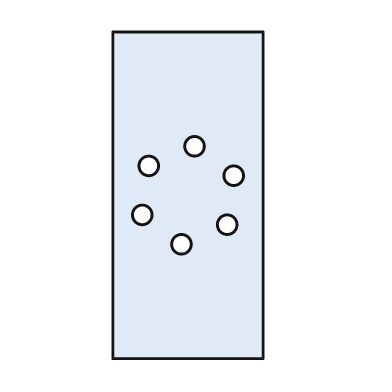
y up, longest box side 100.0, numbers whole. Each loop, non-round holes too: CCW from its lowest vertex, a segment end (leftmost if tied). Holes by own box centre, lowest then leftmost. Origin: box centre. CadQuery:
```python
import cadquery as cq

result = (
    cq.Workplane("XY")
    .moveTo(-23.0, -50.0)
    .lineTo(23.0, -50.0)
    .lineTo(23.0, 50.0)
    .lineTo(-23.0, 50.0)
    .close()
    .moveTo(-2.0, -15.0)
    .circle(3.0)
    .moveTo(12.0, -9.0)
    .circle(3.0)
    .moveTo(-14.0, -6.0)
    .circle(3.0)
    .moveTo(14.0, 6.0)
    .circle(3.0)
    .moveTo(-12.0, 9.0)
    .circle(3.0)
    .moveTo(2.0, 15.0)
    .circle(3.0)
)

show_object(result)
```